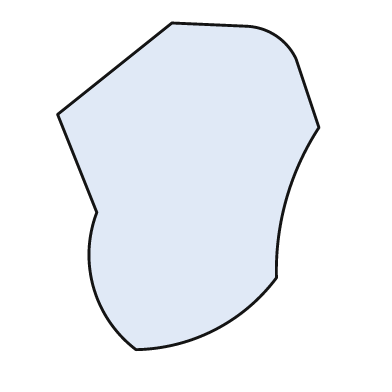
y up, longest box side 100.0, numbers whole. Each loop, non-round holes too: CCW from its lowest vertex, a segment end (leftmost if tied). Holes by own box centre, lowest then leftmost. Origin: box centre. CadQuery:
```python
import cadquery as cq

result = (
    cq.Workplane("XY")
    .moveTo(-16.0, -50.0)
    .threePointArc((8.0, -44.0), (27.0, -28.0))
    .threePointArc((30.0, -4.0), (40.0, 18.0))
    .lineTo(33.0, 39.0)
    .threePointArc((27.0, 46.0), (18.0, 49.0))
    .lineTo(-5.0, 50.0)
    .lineTo(-40.0, 22.0)
    .lineTo(-28.0, -8.0)
    .threePointArc((-29.0, -31.0), (-16.0, -50.0))
    .close()
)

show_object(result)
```